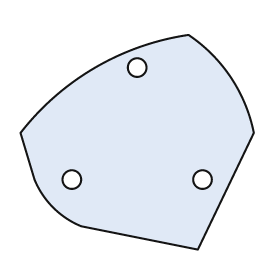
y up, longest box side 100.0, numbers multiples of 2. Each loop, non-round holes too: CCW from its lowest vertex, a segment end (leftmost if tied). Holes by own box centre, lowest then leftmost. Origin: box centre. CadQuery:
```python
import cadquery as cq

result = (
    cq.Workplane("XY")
    .moveTo(26.0, -46.0)
    .lineTo(50.0, 4.0)
    .threePointArc((40.0, 28.0), (22.0, 46.0))
    .threePointArc((-18.0, 32.0), (-50.0, 4.0))
    .lineTo(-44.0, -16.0)
    .threePointArc((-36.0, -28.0), (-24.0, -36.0))
    .close()
    .moveTo(-28.0, -16.0)
    .circle(4.0)
    .moveTo(28.0, -16.0)
    .circle(4.0)
    .moveTo(0.0, 32.0)
    .circle(4.0)
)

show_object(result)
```